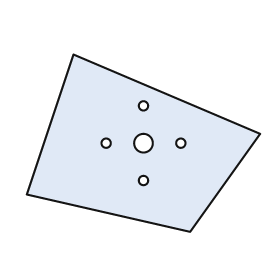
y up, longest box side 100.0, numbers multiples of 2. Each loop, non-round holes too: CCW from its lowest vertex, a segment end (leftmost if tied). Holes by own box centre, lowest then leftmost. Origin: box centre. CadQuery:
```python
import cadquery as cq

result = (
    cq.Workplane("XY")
    .moveTo(20.0, -38.0)
    .lineTo(50.0, 4.0)
    .lineTo(-30.0, 38.0)
    .lineTo(-50.0, -22.0)
    .close()
    .moveTo(0.0, -16.0)
    .circle(2.0)
    .moveTo(-16.0, 0.0)
    .circle(2.0)
    .moveTo(0.0, 0.0)
    .circle(4.0)
    .moveTo(16.0, 0.0)
    .circle(2.0)
    .moveTo(0.0, 16.0)
    .circle(2.0)
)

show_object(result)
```